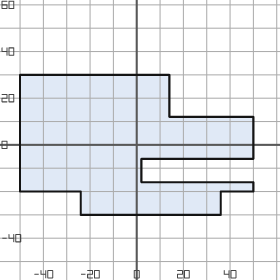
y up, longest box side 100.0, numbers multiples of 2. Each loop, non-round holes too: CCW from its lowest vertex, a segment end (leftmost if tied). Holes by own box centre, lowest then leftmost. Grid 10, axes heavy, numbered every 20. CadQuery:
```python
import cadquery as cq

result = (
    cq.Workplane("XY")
    .moveTo(-24.0, -30.0)
    .lineTo(36.0, -30.0)
    .lineTo(36.0, -20.0)
    .lineTo(50.0, -20.0)
    .lineTo(50.0, -16.0)
    .lineTo(2.0, -16.0)
    .lineTo(2.0, -6.0)
    .lineTo(50.0, -6.0)
    .lineTo(50.0, 12.0)
    .lineTo(14.0, 12.0)
    .lineTo(14.0, 30.0)
    .lineTo(-50.0, 30.0)
    .lineTo(-50.0, -20.0)
    .lineTo(-24.0, -20.0)
    .close()
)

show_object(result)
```